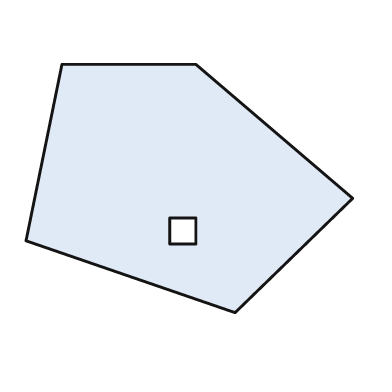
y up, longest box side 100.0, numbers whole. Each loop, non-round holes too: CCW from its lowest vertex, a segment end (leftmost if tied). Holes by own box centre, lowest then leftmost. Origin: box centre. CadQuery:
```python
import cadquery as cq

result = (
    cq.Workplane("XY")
    .moveTo(14.0, -38.0)
    .lineTo(50.0, -3.0)
    .lineTo(2.0, 38.0)
    .lineTo(-39.0, 38.0)
    .lineTo(-50.0, -16.0)
    .close()
    .moveTo(-6.0, -17.0)
    .lineTo(2.0, -17.0)
    .lineTo(2.0, -9.0)
    .lineTo(-6.0, -9.0)
    .close()
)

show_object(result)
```